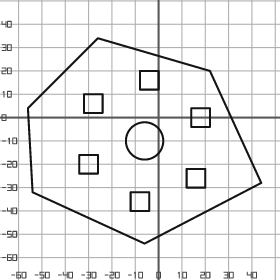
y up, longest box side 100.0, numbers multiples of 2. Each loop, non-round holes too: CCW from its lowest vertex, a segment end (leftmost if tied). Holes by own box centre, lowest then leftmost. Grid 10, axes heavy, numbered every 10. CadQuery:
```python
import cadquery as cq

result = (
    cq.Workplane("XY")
    .moveTo(-6.0, -54.0)
    .lineTo(44.0, -28.0)
    .lineTo(22.0, 20.0)
    .lineTo(-26.0, 34.0)
    .lineTo(-56.0, 4.0)
    .lineTo(-54.0, -32.0)
    .close()
    .moveTo(-12.0, -40.0)
    .lineTo(-4.0, -40.0)
    .lineTo(-4.0, -32.0)
    .lineTo(-12.0, -32.0)
    .close()
    .moveTo(12.0, -30.0)
    .lineTo(20.0, -30.0)
    .lineTo(20.0, -22.0)
    .lineTo(12.0, -22.0)
    .close()
    .moveTo(-34.0, -24.0)
    .lineTo(-26.0, -24.0)
    .lineTo(-26.0, -16.0)
    .lineTo(-34.0, -16.0)
    .close()
    .moveTo(-6.0, -10.0)
    .circle(8.0)
    .moveTo(14.0, -4.0)
    .lineTo(22.0, -4.0)
    .lineTo(22.0, 4.0)
    .lineTo(14.0, 4.0)
    .close()
    .moveTo(-32.0, 2.0)
    .lineTo(-24.0, 2.0)
    .lineTo(-24.0, 10.0)
    .lineTo(-32.0, 10.0)
    .close()
    .moveTo(-8.0, 12.0)
    .lineTo(0.0, 12.0)
    .lineTo(0.0, 20.0)
    .lineTo(-8.0, 20.0)
    .close()
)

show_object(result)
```